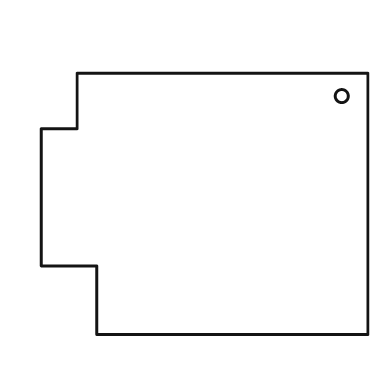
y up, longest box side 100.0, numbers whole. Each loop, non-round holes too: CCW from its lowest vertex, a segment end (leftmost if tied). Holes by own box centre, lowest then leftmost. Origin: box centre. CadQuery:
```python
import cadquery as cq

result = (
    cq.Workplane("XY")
    .moveTo(-33.0, -40.0)
    .lineTo(50.0, -40.0)
    .lineTo(50.0, 40.0)
    .lineTo(-39.0, 40.0)
    .lineTo(-39.0, 23.0)
    .lineTo(-50.0, 23.0)
    .lineTo(-50.0, -19.0)
    .lineTo(-33.0, -19.0)
    .close()
    .moveTo(42.0, 33.0)
    .circle(2.0)
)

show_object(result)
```